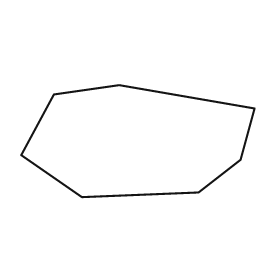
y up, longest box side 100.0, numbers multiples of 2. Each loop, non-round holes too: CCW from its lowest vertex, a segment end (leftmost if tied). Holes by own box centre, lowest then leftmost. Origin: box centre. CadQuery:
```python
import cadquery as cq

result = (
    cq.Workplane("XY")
    .moveTo(-24.0, -24.0)
    .lineTo(26.0, -22.0)
    .lineTo(44.0, -8.0)
    .lineTo(50.0, 14.0)
    .lineTo(-8.0, 24.0)
    .lineTo(-36.0, 20.0)
    .lineTo(-50.0, -6.0)
    .close()
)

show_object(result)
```